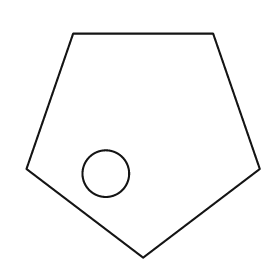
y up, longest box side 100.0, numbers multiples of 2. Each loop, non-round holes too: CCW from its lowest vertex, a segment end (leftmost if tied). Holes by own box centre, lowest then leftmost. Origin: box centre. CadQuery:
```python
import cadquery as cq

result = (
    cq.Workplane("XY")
    .moveTo(0.0, -48.0)
    .lineTo(50.0, -10.0)
    .lineTo(30.0, 48.0)
    .lineTo(-30.0, 48.0)
    .lineTo(-50.0, -10.0)
    .close()
    .moveTo(-16.0, -12.0)
    .circle(10.0)
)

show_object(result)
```